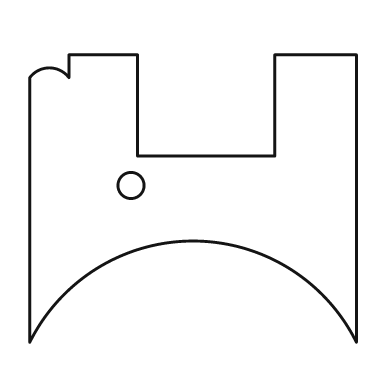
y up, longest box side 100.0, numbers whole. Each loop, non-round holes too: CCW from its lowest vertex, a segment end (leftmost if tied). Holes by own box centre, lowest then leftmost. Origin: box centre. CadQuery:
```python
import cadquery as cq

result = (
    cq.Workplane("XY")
    .moveTo(-50.0, -44.0)
    .threePointArc((0.0, -13.0), (50.0, -44.0))
    .lineTo(50.0, 44.0)
    .lineTo(25.0, 44.0)
    .lineTo(25.0, 13.0)
    .lineTo(-17.0, 13.0)
    .lineTo(-17.0, 44.0)
    .lineTo(-38.0, 44.0)
    .lineTo(-38.0, 37.0)
    .threePointArc((-44.0, 40.0), (-50.0, 37.0))
    .close()
    .moveTo(-19.0, 4.0)
    .circle(4.0)
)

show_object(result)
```